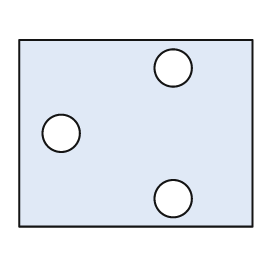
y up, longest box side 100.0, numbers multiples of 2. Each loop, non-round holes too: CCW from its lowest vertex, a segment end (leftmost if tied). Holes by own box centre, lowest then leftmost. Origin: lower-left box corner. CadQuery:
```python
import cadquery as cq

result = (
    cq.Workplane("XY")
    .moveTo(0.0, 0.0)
    .lineTo(100.0, 0.0)
    .lineTo(100.0, 80.0)
    .lineTo(0.0, 80.0)
    .close()
    .moveTo(66.0, 12.0)
    .circle(8.0)
    .moveTo(18.0, 40.0)
    .circle(8.0)
    .moveTo(66.0, 68.0)
    .circle(8.0)
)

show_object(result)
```